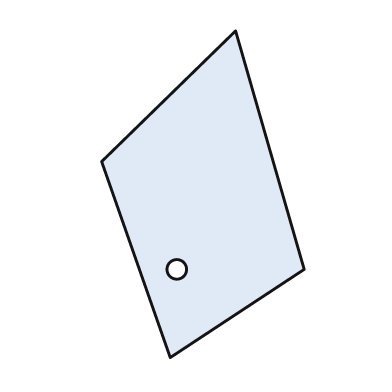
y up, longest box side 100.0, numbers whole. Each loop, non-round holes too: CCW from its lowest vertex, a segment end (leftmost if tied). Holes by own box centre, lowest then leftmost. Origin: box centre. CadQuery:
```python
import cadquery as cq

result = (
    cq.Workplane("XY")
    .moveTo(-10.0, -50.0)
    .lineTo(31.0, -23.0)
    .lineTo(10.0, 50.0)
    .lineTo(-31.0, 10.0)
    .close()
    .moveTo(-8.0, -23.0)
    .circle(3.0)
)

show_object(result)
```